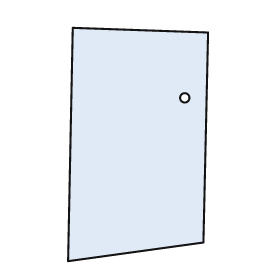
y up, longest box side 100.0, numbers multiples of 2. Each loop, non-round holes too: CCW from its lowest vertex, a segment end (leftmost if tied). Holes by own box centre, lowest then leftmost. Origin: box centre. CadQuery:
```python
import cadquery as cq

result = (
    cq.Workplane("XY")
    .moveTo(-30.0, -50.0)
    .lineTo(28.0, -42.0)
    .lineTo(30.0, 48.0)
    .lineTo(-28.0, 50.0)
    .close()
    .moveTo(20.0, 20.0)
    .circle(2.0)
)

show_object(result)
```